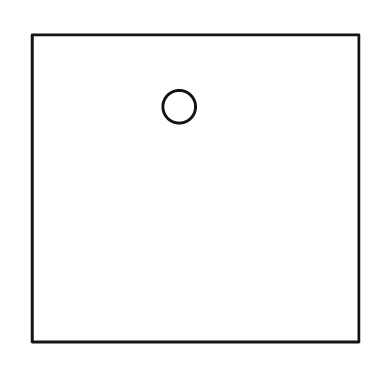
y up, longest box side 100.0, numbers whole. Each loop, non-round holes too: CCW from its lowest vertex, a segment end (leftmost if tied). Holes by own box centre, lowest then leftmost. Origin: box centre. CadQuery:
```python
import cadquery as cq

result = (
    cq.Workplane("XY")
    .moveTo(-50.0, -47.0)
    .lineTo(50.0, -47.0)
    .lineTo(50.0, 47.0)
    .lineTo(-50.0, 47.0)
    .close()
    .moveTo(-5.0, 25.0)
    .circle(5.0)
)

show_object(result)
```